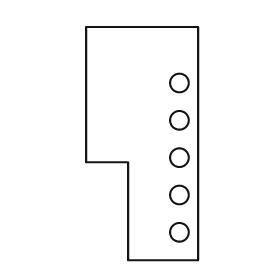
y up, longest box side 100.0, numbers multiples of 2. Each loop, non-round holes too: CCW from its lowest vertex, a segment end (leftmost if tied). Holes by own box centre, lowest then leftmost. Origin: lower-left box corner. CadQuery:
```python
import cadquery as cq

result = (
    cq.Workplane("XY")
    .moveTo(18.0, 0.0)
    .lineTo(48.0, 0.0)
    .lineTo(48.0, 100.0)
    .lineTo(0.0, 100.0)
    .lineTo(0.0, 42.0)
    .lineTo(18.0, 42.0)
    .close()
    .moveTo(40.0, 12.0)
    .circle(4.0)
    .moveTo(40.0, 28.0)
    .circle(4.0)
    .moveTo(40.0, 44.0)
    .circle(4.0)
    .moveTo(40.0, 60.0)
    .circle(4.0)
    .moveTo(40.0, 76.0)
    .circle(4.0)
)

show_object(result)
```